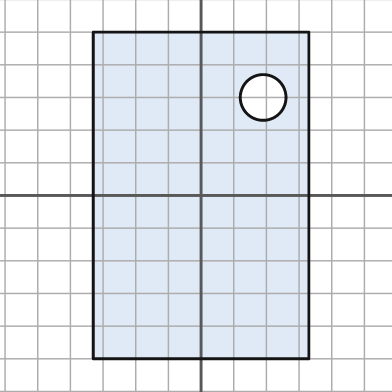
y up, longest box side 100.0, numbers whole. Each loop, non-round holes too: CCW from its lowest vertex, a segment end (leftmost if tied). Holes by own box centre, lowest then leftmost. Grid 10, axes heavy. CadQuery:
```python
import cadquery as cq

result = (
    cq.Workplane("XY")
    .moveTo(-33.0, -50.0)
    .lineTo(33.0, -50.0)
    .lineTo(33.0, 50.0)
    .lineTo(-33.0, 50.0)
    .close()
    .moveTo(19.0, 30.0)
    .circle(7.0)
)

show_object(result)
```